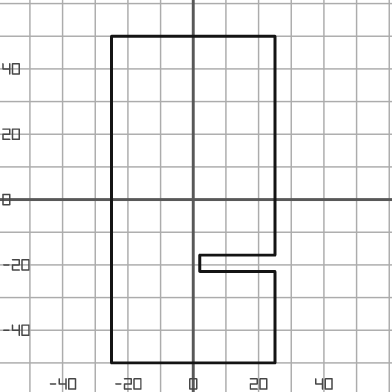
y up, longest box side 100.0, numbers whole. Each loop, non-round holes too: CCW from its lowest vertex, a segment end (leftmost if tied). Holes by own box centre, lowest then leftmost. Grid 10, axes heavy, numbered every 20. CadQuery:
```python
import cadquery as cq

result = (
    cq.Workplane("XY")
    .moveTo(-25.0, -50.0)
    .lineTo(25.0, -50.0)
    .lineTo(25.0, -22.0)
    .lineTo(2.0, -22.0)
    .lineTo(2.0, -17.0)
    .lineTo(25.0, -17.0)
    .lineTo(25.0, 50.0)
    .lineTo(-25.0, 50.0)
    .close()
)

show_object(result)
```